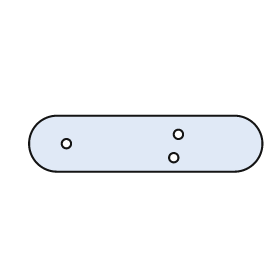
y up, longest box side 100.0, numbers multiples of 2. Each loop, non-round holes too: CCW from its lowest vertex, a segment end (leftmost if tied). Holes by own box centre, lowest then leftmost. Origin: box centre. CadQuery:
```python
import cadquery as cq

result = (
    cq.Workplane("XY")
    .moveTo(-38.0, -12.0)
    .lineTo(38.0, -12.0)
    .threePointArc((50.0, 0.0), (38.0, 12.0))
    .lineTo(-38.0, 12.0)
    .threePointArc((-50.0, 0.0), (-38.0, -12.0))
    .close()
    .moveTo(12.0, -6.0)
    .circle(2.0)
    .moveTo(-34.0, 0.0)
    .circle(2.0)
    .moveTo(14.0, 4.0)
    .circle(2.0)
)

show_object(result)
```